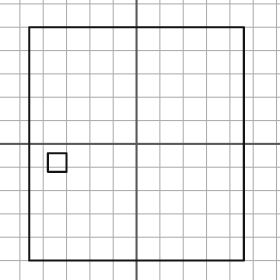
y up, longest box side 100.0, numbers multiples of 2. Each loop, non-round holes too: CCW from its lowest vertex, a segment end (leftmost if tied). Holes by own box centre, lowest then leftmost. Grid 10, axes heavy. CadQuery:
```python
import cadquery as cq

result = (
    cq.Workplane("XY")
    .moveTo(-46.0, -50.0)
    .lineTo(46.0, -50.0)
    .lineTo(46.0, 50.0)
    .lineTo(-46.0, 50.0)
    .close()
    .moveTo(-38.0, -12.0)
    .lineTo(-30.0, -12.0)
    .lineTo(-30.0, -4.0)
    .lineTo(-38.0, -4.0)
    .close()
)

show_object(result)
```